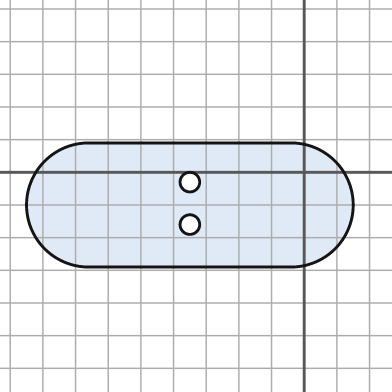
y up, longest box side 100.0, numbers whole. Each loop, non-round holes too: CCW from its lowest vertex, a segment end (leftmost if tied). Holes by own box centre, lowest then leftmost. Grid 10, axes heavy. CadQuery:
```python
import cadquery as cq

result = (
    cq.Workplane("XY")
    .moveTo(-66.0, -29.0)
    .lineTo(-4.0, -29.0)
    .threePointArc((15.0, -10.0), (-4.0, 9.0))
    .lineTo(-66.0, 9.0)
    .threePointArc((-85.0, -10.0), (-66.0, -29.0))
    .close()
    .moveTo(-35.0, -16.0)
    .circle(3.0)
    .moveTo(-35.0, -3.0)
    .circle(3.0)
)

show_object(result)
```